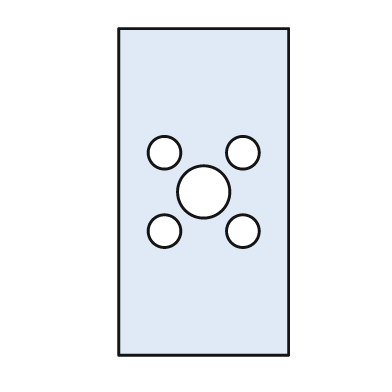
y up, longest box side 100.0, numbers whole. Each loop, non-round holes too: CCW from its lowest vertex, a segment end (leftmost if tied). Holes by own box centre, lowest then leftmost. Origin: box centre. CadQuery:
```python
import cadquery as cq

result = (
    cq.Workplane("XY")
    .moveTo(-26.0, -50.0)
    .lineTo(26.0, -50.0)
    .lineTo(26.0, 50.0)
    .lineTo(-26.0, 50.0)
    .close()
    .moveTo(-12.0, -12.0)
    .circle(5.0)
    .moveTo(12.0, -12.0)
    .circle(5.0)
    .moveTo(0.0, 0.0)
    .circle(8.0)
    .moveTo(-12.0, 12.0)
    .circle(5.0)
    .moveTo(12.0, 12.0)
    .circle(5.0)
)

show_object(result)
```